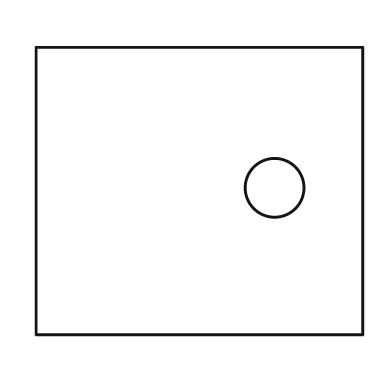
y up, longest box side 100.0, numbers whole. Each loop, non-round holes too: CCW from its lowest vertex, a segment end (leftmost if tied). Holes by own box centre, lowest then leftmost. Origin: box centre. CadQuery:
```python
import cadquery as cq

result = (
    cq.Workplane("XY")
    .moveTo(-50.0, -44.0)
    .lineTo(50.0, -44.0)
    .lineTo(50.0, 44.0)
    .lineTo(-50.0, 44.0)
    .close()
    .moveTo(23.0, 1.0)
    .circle(9.0)
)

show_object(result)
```